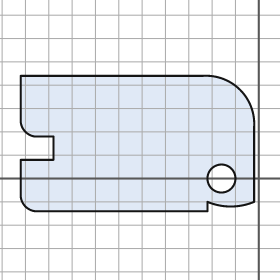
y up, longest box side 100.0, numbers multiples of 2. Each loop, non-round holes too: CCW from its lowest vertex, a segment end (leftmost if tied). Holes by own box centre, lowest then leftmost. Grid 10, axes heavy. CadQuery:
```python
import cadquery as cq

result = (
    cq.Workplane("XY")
    .moveTo(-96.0, -14.0)
    .lineTo(-22.0, -14.0)
    .lineTo(-22.0, -10.0)
    .threePointArc((-12.0, -12.0), (-2.0, -10.0))
    .lineTo(-2.0, 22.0)
    .threePointArc((-8.0, 38.0), (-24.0, 44.0))
    .lineTo(-102.0, 44.0)
    .lineTo(-102.0, 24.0)
    .threePointArc((-100.0, 20.0), (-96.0, 18.0))
    .lineTo(-88.0, 18.0)
    .lineTo(-88.0, 8.0)
    .lineTo(-102.0, 8.0)
    .lineTo(-102.0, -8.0)
    .threePointArc((-100.0, -12.0), (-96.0, -14.0))
    .close()
    .moveTo(-16.0, 0.0)
    .circle(6.0)
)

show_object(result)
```